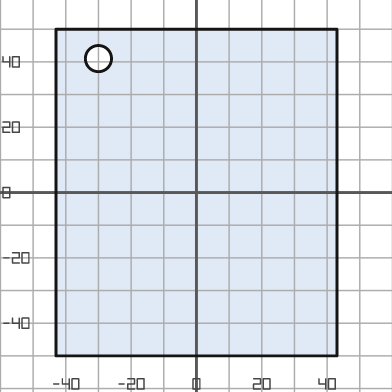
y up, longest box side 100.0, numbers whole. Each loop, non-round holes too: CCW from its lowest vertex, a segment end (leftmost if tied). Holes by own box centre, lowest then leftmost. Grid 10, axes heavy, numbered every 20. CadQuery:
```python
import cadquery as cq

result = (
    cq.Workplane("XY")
    .moveTo(-43.0, -50.0)
    .lineTo(43.0, -50.0)
    .lineTo(43.0, 50.0)
    .lineTo(-43.0, 50.0)
    .close()
    .moveTo(-30.0, 41.0)
    .circle(4.0)
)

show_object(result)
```